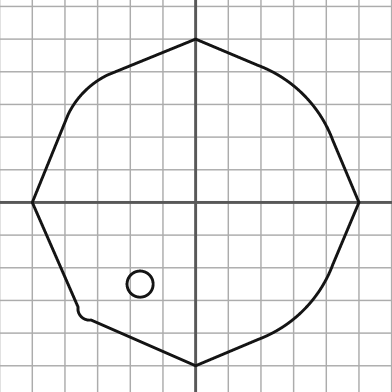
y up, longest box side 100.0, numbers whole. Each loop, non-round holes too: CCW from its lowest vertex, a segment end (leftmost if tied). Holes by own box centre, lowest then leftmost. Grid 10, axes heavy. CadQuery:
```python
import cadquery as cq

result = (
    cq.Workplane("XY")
    .moveTo(0.0, -50.0)
    .lineTo(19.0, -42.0)
    .threePointArc((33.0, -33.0), (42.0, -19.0))
    .lineTo(50.0, 0.0)
    .lineTo(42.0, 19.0)
    .threePointArc((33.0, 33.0), (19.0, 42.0))
    .lineTo(0.0, 50.0)
    .lineTo(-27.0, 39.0)
    .threePointArc((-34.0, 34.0), (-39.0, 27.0))
    .lineTo(-50.0, 0.0)
    .lineTo(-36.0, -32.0)
    .threePointArc((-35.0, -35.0), (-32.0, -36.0))
    .close()
    .moveTo(-17.0, -25.0)
    .circle(4.0)
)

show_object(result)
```